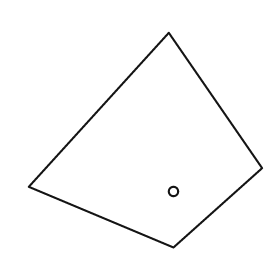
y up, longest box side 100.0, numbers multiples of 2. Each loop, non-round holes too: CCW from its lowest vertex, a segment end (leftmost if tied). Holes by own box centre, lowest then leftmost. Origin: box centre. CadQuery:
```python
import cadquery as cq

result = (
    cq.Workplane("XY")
    .moveTo(12.0, -46.0)
    .lineTo(50.0, -12.0)
    .lineTo(10.0, 46.0)
    .lineTo(-50.0, -20.0)
    .close()
    .moveTo(12.0, -22.0)
    .circle(2.0)
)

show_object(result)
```